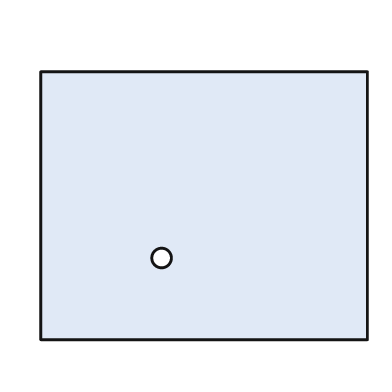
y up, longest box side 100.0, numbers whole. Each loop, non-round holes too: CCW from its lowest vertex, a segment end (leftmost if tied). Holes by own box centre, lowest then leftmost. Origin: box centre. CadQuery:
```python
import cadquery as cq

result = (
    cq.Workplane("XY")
    .moveTo(-50.0, -41.0)
    .lineTo(50.0, -41.0)
    .lineTo(50.0, 41.0)
    .lineTo(-50.0, 41.0)
    .close()
    .moveTo(-13.0, -16.0)
    .circle(3.0)
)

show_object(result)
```